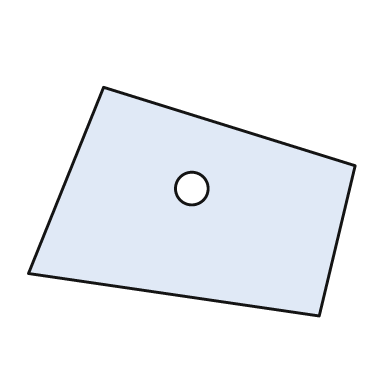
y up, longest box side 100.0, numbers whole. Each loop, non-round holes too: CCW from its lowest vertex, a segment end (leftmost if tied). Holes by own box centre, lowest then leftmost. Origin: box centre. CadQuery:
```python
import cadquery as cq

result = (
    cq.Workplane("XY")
    .moveTo(39.0, -35.0)
    .lineTo(50.0, 11.0)
    .lineTo(-27.0, 35.0)
    .lineTo(-50.0, -22.0)
    .close()
    .moveTo(0.0, 4.0)
    .circle(5.0)
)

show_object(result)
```